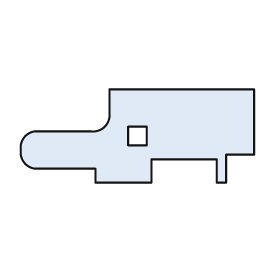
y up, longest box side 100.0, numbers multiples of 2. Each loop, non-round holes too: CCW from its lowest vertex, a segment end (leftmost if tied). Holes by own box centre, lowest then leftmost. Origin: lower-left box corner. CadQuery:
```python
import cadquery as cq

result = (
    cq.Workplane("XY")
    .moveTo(32.0, 0.0)
    .lineTo(56.0, 0.0)
    .lineTo(56.0, 10.0)
    .lineTo(84.0, 10.0)
    .lineTo(84.0, 0.0)
    .lineTo(88.0, 0.0)
    .lineTo(88.0, 12.0)
    .lineTo(100.0, 12.0)
    .lineTo(100.0, 40.0)
    .lineTo(38.0, 40.0)
    .lineTo(38.0, 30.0)
    .threePointArc((36.0, 24.0), (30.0, 22.0))
    .lineTo(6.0, 22.0)
    .threePointArc((2.0, 20.0), (0.0, 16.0))
    .lineTo(0.0, 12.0)
    .threePointArc((2.0, 8.0), (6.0, 6.0))
    .lineTo(32.0, 6.0)
    .close()
    .moveTo(46.0, 16.0)
    .lineTo(54.0, 16.0)
    .lineTo(54.0, 24.0)
    .lineTo(46.0, 24.0)
    .close()
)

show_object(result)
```